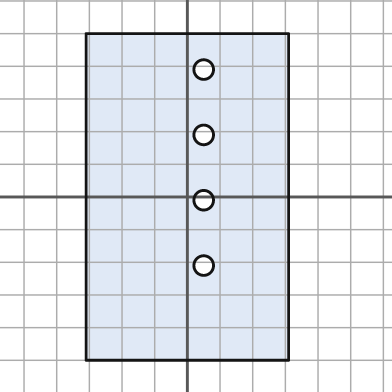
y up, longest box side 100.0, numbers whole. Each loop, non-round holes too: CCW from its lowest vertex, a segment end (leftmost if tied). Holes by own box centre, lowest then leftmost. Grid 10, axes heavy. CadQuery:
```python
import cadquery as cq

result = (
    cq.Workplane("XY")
    .moveTo(-31.0, -50.0)
    .lineTo(31.0, -50.0)
    .lineTo(31.0, 50.0)
    .lineTo(-31.0, 50.0)
    .close()
    .moveTo(5.0, -21.0)
    .circle(3.0)
    .moveTo(5.0, -1.0)
    .circle(3.0)
    .moveTo(5.0, 19.0)
    .circle(3.0)
    .moveTo(5.0, 39.0)
    .circle(3.0)
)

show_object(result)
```